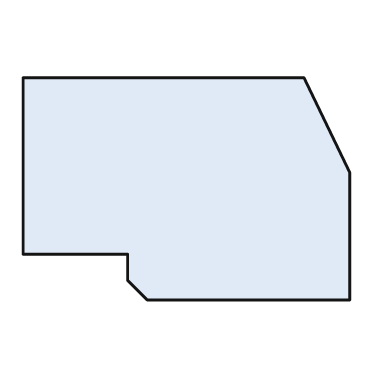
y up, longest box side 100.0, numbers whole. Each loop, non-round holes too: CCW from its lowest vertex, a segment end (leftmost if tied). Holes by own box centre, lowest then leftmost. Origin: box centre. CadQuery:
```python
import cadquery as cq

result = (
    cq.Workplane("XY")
    .moveTo(-12.0, -34.0)
    .lineTo(50.0, -34.0)
    .lineTo(50.0, 5.0)
    .lineTo(36.0, 34.0)
    .lineTo(-50.0, 34.0)
    .lineTo(-50.0, -20.0)
    .lineTo(-18.0, -20.0)
    .lineTo(-18.0, -28.0)
    .close()
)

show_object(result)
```